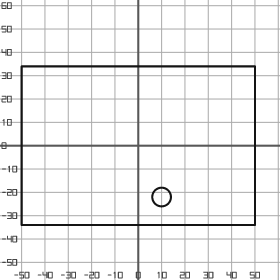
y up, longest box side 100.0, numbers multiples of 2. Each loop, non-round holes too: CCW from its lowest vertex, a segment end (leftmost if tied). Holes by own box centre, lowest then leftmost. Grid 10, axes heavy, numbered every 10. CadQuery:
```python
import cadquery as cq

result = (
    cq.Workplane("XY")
    .moveTo(-50.0, -34.0)
    .lineTo(50.0, -34.0)
    .lineTo(50.0, 34.0)
    .lineTo(-50.0, 34.0)
    .close()
    .moveTo(10.0, -22.0)
    .circle(4.0)
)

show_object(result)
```